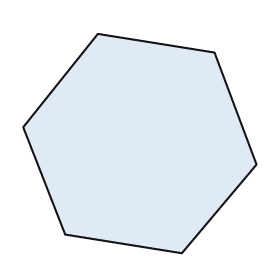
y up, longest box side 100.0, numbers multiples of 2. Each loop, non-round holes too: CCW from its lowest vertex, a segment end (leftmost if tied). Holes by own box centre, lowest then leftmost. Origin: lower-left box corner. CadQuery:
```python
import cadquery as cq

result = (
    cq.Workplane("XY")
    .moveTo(68.0, 0.0)
    .lineTo(100.0, 38.0)
    .lineTo(82.0, 86.0)
    .lineTo(32.0, 94.0)
    .lineTo(0.0, 54.0)
    .lineTo(18.0, 8.0)
    .close()
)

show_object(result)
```